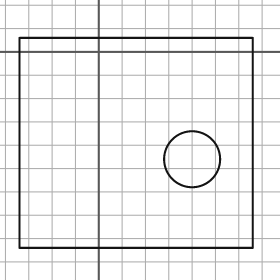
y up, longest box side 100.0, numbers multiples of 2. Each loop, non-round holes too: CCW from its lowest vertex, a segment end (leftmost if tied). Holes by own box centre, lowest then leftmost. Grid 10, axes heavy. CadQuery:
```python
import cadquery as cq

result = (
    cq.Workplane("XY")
    .moveTo(-34.0, -84.0)
    .lineTo(66.0, -84.0)
    .lineTo(66.0, 6.0)
    .lineTo(-34.0, 6.0)
    .close()
    .moveTo(40.0, -46.0)
    .circle(12.0)
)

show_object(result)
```